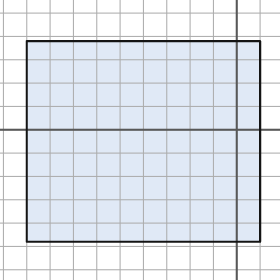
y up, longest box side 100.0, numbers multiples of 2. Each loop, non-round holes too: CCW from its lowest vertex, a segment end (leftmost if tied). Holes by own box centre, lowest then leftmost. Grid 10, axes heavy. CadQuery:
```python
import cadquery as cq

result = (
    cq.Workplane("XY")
    .moveTo(-90.0, -48.0)
    .lineTo(10.0, -48.0)
    .lineTo(10.0, 38.0)
    .lineTo(-90.0, 38.0)
    .close()
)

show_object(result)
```